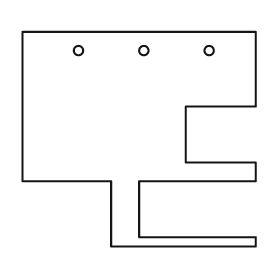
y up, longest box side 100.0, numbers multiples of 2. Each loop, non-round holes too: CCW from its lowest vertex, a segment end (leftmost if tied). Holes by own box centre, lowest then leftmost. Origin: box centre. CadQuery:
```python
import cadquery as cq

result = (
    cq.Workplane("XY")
    .moveTo(-12.0, -46.0)
    .lineTo(50.0, -46.0)
    .lineTo(50.0, -42.0)
    .lineTo(0.0, -42.0)
    .lineTo(0.0, -18.0)
    .lineTo(50.0, -18.0)
    .lineTo(50.0, -10.0)
    .lineTo(20.0, -10.0)
    .lineTo(20.0, 14.0)
    .lineTo(50.0, 14.0)
    .lineTo(50.0, 46.0)
    .lineTo(-50.0, 46.0)
    .lineTo(-50.0, -18.0)
    .lineTo(-12.0, -18.0)
    .close()
    .moveTo(-26.0, 38.0)
    .circle(2.0)
    .moveTo(2.0, 38.0)
    .circle(2.0)
    .moveTo(30.0, 38.0)
    .circle(2.0)
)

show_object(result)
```